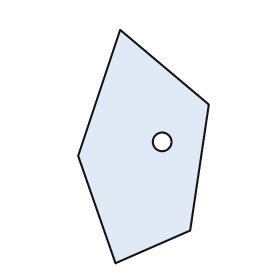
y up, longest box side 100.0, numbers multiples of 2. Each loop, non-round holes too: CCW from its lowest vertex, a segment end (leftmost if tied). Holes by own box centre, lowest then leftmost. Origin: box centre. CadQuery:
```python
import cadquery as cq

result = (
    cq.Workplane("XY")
    .moveTo(-12.0, -50.0)
    .lineTo(20.0, -36.0)
    .lineTo(28.0, 18.0)
    .lineTo(-10.0, 50.0)
    .lineTo(-28.0, -4.0)
    .close()
    .moveTo(8.0, 2.0)
    .circle(4.0)
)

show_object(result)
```